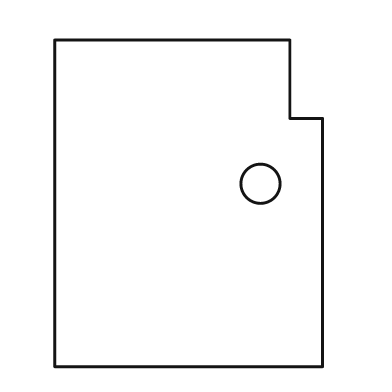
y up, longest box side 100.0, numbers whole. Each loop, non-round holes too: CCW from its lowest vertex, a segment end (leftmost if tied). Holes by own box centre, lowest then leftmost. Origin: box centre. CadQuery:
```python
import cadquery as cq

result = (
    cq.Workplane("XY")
    .moveTo(-41.0, -50.0)
    .lineTo(41.0, -50.0)
    .lineTo(41.0, 26.0)
    .lineTo(31.0, 26.0)
    .lineTo(31.0, 50.0)
    .lineTo(-41.0, 50.0)
    .close()
    .moveTo(22.0, 6.0)
    .circle(6.0)
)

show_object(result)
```